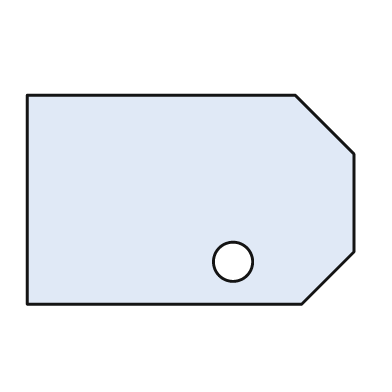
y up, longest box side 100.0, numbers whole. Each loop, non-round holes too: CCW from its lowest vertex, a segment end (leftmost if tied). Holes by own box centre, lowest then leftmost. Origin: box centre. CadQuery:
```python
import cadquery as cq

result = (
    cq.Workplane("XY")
    .moveTo(-50.0, -32.0)
    .lineTo(34.0, -32.0)
    .lineTo(50.0, -16.0)
    .lineTo(50.0, 14.0)
    .lineTo(32.0, 32.0)
    .lineTo(-50.0, 32.0)
    .close()
    .moveTo(13.0, -19.0)
    .circle(6.0)
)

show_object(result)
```